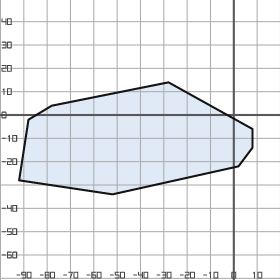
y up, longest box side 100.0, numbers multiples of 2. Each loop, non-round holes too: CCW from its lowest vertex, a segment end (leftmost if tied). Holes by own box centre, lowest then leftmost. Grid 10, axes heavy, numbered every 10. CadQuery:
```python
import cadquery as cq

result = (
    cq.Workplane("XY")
    .moveTo(-52.0, -34.0)
    .lineTo(2.0, -22.0)
    .lineTo(8.0, -14.0)
    .lineTo(8.0, -6.0)
    .lineTo(-28.0, 14.0)
    .lineTo(-78.0, 4.0)
    .lineTo(-88.0, -2.0)
    .lineTo(-92.0, -28.0)
    .close()
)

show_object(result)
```